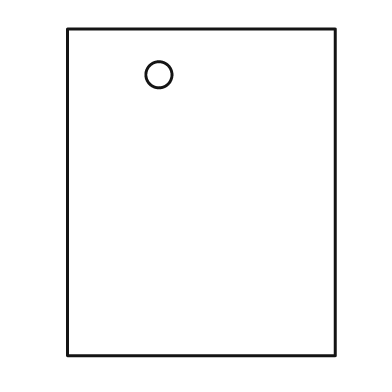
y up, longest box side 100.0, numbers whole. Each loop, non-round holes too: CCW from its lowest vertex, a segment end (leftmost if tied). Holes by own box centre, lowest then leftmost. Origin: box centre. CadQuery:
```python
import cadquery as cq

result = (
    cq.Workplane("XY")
    .moveTo(-41.0, -50.0)
    .lineTo(41.0, -50.0)
    .lineTo(41.0, 50.0)
    .lineTo(-41.0, 50.0)
    .close()
    .moveTo(-13.0, 36.0)
    .circle(4.0)
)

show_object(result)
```